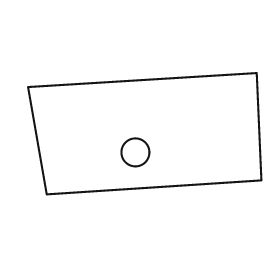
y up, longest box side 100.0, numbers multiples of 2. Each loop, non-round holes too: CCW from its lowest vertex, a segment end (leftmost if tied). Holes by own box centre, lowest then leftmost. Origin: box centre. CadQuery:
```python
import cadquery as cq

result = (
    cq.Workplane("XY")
    .moveTo(-42.0, -26.0)
    .lineTo(50.0, -20.0)
    .lineTo(48.0, 26.0)
    .lineTo(-50.0, 20.0)
    .close()
    .moveTo(-4.0, -8.0)
    .circle(6.0)
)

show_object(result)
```